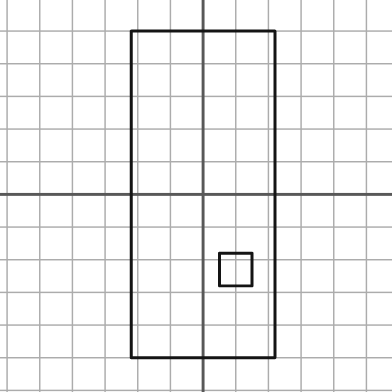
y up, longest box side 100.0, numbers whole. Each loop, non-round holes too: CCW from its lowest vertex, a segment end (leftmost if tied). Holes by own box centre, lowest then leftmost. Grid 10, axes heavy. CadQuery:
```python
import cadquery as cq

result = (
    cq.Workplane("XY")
    .moveTo(-22.0, -50.0)
    .lineTo(22.0, -50.0)
    .lineTo(22.0, 50.0)
    .lineTo(-22.0, 50.0)
    .close()
    .moveTo(5.0, -28.0)
    .lineTo(15.0, -28.0)
    .lineTo(15.0, -18.0)
    .lineTo(5.0, -18.0)
    .close()
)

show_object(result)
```